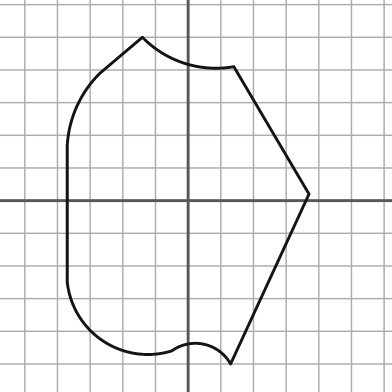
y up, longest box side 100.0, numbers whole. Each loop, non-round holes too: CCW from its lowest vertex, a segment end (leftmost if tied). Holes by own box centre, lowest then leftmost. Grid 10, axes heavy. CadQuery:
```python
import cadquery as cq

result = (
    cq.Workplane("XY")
    .moveTo(13.0, -50.0)
    .lineTo(37.0, 2.0)
    .lineTo(14.0, 41.0)
    .threePointArc((-1.0, 42.0), (-14.0, 50.0))
    .lineTo(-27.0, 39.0)
    .threePointArc((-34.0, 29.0), (-37.0, 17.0))
    .lineTo(-37.0, -25.0)
    .threePointArc((-26.0, -43.0), (-5.0, -46.0))
    .threePointArc((5.0, -44.0), (13.0, -50.0))
    .close()
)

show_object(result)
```